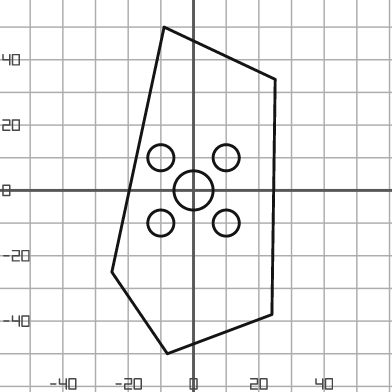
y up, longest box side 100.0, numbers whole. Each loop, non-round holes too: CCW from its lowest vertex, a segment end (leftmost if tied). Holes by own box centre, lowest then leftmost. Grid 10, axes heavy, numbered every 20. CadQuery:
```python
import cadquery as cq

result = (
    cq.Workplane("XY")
    .moveTo(-8.0, -50.0)
    .lineTo(24.0, -38.0)
    .lineTo(25.0, 34.0)
    .lineTo(-9.0, 50.0)
    .lineTo(-25.0, -25.0)
    .close()
    .moveTo(-10.0, -10.0)
    .circle(4.0)
    .moveTo(10.0, -10.0)
    .circle(4.0)
    .moveTo(0.0, 0.0)
    .circle(6.0)
    .moveTo(-10.0, 10.0)
    .circle(4.0)
    .moveTo(10.0, 10.0)
    .circle(4.0)
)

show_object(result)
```